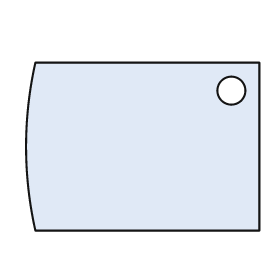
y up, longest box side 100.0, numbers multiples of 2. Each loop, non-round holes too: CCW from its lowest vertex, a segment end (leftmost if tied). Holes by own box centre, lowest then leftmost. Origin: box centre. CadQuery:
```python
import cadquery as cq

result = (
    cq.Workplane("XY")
    .moveTo(-46.0, -36.0)
    .lineTo(50.0, -36.0)
    .lineTo(50.0, 36.0)
    .lineTo(-46.0, 36.0)
    .threePointArc((-50.0, 0.0), (-46.0, -36.0))
    .close()
    .moveTo(38.0, 24.0)
    .circle(6.0)
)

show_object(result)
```